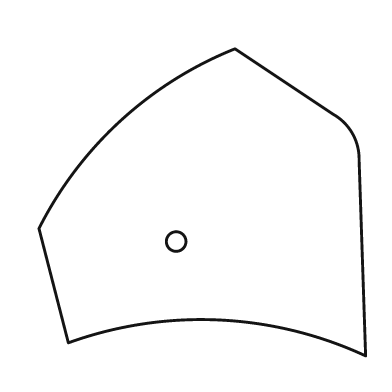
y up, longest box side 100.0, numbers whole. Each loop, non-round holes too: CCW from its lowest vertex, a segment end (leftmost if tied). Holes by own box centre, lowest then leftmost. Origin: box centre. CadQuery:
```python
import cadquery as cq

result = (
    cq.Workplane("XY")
    .moveTo(50.0, -47.0)
    .lineTo(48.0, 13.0)
    .threePointArc((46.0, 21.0), (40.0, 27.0))
    .lineTo(10.0, 47.0)
    .threePointArc((-25.0, 25.0), (-50.0, -8.0))
    .lineTo(-41.0, -43.0)
    .threePointArc((5.0, -36.0), (50.0, -47.0))
    .close()
    .moveTo(-8.0, -12.0)
    .circle(3.0)
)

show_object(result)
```